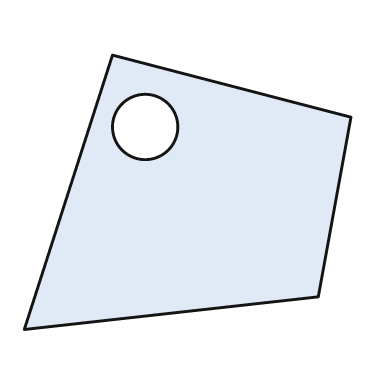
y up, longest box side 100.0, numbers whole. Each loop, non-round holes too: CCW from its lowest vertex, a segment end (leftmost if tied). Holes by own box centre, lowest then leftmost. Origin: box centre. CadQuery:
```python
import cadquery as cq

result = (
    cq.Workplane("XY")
    .moveTo(-50.0, -42.0)
    .lineTo(40.0, -32.0)
    .lineTo(50.0, 23.0)
    .lineTo(-23.0, 42.0)
    .close()
    .moveTo(-13.0, 20.0)
    .circle(10.0)
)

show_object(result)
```